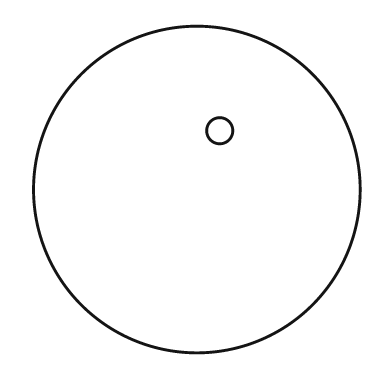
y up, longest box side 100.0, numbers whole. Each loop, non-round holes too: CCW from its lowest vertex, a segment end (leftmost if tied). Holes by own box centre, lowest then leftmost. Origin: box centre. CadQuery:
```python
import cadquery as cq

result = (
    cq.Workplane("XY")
    .moveTo(0.0, 0.0)
    .circle(50.0)
    .moveTo(7.0, 18.0)
    .circle(4.0)
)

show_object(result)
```